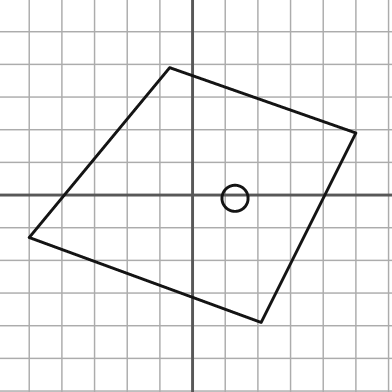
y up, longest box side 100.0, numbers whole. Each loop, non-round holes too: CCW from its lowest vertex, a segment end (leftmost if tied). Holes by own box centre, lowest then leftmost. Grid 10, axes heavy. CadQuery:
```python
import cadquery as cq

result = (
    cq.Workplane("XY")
    .moveTo(21.0, -39.0)
    .lineTo(50.0, 19.0)
    .lineTo(-7.0, 39.0)
    .lineTo(-50.0, -13.0)
    .close()
    .moveTo(13.0, -1.0)
    .circle(4.0)
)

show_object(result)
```